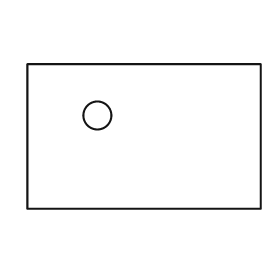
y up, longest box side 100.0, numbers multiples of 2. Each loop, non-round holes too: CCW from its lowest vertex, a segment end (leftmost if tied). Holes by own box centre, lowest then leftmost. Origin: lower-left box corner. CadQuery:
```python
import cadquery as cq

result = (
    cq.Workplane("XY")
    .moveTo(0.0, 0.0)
    .lineTo(100.0, 0.0)
    .lineTo(100.0, 62.0)
    .lineTo(0.0, 62.0)
    .close()
    .moveTo(30.0, 40.0)
    .circle(6.0)
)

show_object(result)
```